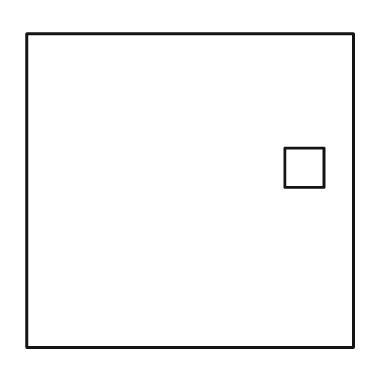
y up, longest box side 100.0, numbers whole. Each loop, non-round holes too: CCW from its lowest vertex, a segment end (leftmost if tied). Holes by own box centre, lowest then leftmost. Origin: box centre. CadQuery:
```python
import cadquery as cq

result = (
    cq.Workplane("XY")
    .moveTo(-50.0, -48.0)
    .lineTo(50.0, -48.0)
    .lineTo(50.0, 48.0)
    .lineTo(-50.0, 48.0)
    .close()
    .moveTo(29.0, 1.0)
    .lineTo(41.0, 1.0)
    .lineTo(41.0, 13.0)
    .lineTo(29.0, 13.0)
    .close()
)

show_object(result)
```